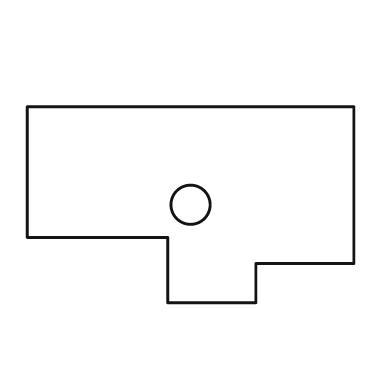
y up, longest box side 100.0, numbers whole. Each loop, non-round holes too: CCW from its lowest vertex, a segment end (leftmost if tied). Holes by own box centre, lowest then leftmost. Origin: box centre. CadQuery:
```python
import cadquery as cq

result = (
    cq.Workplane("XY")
    .moveTo(-7.0, -30.0)
    .lineTo(20.0, -30.0)
    .lineTo(20.0, -18.0)
    .lineTo(50.0, -18.0)
    .lineTo(50.0, 30.0)
    .lineTo(-50.0, 30.0)
    .lineTo(-50.0, -10.0)
    .lineTo(-7.0, -10.0)
    .close()
    .moveTo(0.0, 0.0)
    .circle(6.0)
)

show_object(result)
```